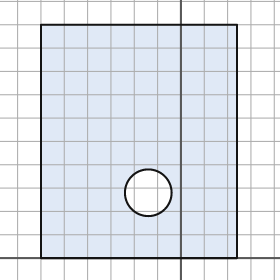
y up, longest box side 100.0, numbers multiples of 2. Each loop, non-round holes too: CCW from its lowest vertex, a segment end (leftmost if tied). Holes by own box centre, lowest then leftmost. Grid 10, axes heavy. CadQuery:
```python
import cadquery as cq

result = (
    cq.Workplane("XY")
    .moveTo(-60.0, 0.0)
    .lineTo(24.0, 0.0)
    .lineTo(24.0, 100.0)
    .lineTo(-60.0, 100.0)
    .close()
    .moveTo(-14.0, 28.0)
    .circle(10.0)
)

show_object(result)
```